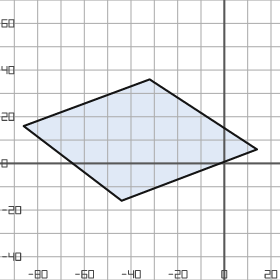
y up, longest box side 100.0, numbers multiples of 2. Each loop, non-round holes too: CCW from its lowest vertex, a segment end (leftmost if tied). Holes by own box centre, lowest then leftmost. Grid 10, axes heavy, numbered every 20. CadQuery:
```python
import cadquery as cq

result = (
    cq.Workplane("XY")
    .moveTo(-44.0, -16.0)
    .lineTo(14.0, 6.0)
    .lineTo(-32.0, 36.0)
    .lineTo(-86.0, 16.0)
    .close()
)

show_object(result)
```